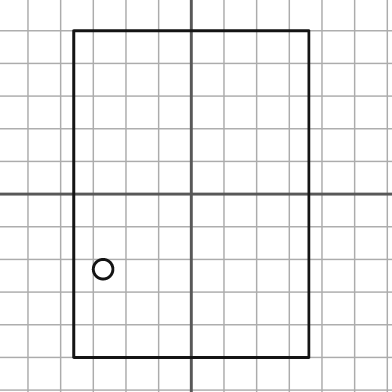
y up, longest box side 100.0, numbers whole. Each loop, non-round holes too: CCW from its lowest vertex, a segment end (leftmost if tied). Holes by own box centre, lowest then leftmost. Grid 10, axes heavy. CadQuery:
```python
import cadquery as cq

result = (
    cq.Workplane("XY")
    .moveTo(-36.0, -50.0)
    .lineTo(36.0, -50.0)
    .lineTo(36.0, 50.0)
    .lineTo(-36.0, 50.0)
    .close()
    .moveTo(-27.0, -23.0)
    .circle(3.0)
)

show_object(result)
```